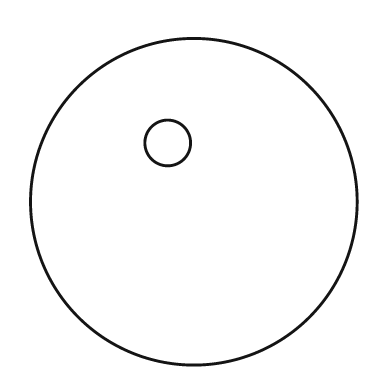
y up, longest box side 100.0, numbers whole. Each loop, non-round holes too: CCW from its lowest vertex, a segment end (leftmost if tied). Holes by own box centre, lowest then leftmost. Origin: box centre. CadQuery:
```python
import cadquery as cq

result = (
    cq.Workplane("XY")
    .moveTo(0.0, 0.0)
    .circle(50.0)
    .moveTo(-8.0, 18.0)
    .circle(7.0)
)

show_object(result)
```